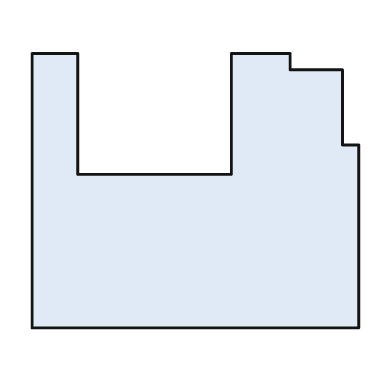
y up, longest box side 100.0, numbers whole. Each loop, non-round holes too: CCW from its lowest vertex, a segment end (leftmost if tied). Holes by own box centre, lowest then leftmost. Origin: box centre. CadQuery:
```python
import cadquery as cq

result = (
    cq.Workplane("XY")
    .moveTo(-50.0, -42.0)
    .lineTo(50.0, -42.0)
    .lineTo(50.0, 14.0)
    .lineTo(45.0, 14.0)
    .lineTo(45.0, 37.0)
    .lineTo(29.0, 37.0)
    .lineTo(29.0, 42.0)
    .lineTo(11.0, 42.0)
    .lineTo(11.0, 5.0)
    .lineTo(-36.0, 5.0)
    .lineTo(-36.0, 42.0)
    .lineTo(-50.0, 42.0)
    .close()
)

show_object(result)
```